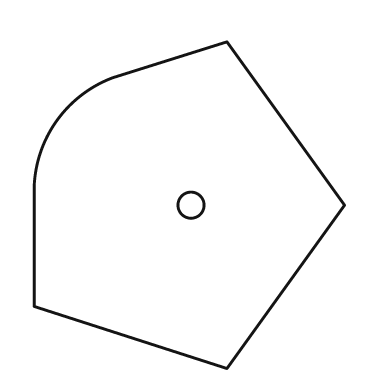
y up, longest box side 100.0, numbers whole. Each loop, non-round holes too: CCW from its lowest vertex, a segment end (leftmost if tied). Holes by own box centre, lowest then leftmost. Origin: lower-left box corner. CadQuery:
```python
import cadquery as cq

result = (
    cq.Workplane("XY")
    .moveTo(59.0, 0.0)
    .lineTo(95.0, 50.0)
    .lineTo(59.0, 100.0)
    .lineTo(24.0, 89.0)
    .threePointArc((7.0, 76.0), (0.0, 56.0))
    .lineTo(0.0, 19.0)
    .close()
    .moveTo(48.0, 50.0)
    .circle(4.0)
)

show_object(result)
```